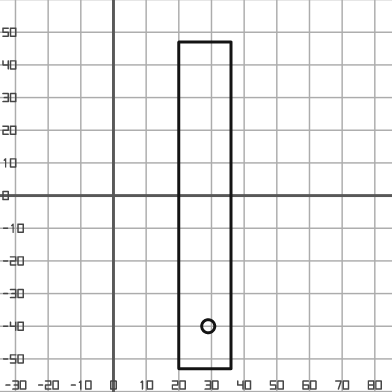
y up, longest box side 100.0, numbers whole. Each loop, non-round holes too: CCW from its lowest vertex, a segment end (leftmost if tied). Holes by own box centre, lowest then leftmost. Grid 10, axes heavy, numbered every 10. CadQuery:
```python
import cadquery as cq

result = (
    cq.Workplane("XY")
    .moveTo(20.0, -53.0)
    .lineTo(36.0, -53.0)
    .lineTo(36.0, 47.0)
    .lineTo(20.0, 47.0)
    .close()
    .moveTo(29.0, -40.0)
    .circle(2.0)
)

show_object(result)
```